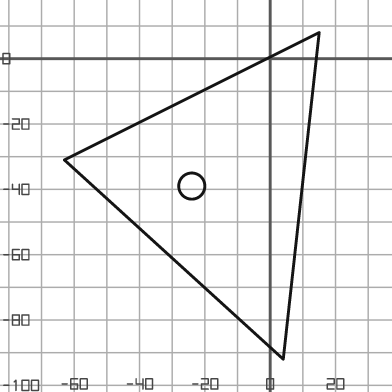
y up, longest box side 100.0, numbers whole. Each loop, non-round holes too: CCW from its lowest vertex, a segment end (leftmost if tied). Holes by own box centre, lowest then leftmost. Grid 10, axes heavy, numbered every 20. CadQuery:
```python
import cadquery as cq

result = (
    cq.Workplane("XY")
    .moveTo(4.0, -92.0)
    .lineTo(15.0, 8.0)
    .lineTo(-63.0, -31.0)
    .close()
    .moveTo(-24.0, -39.0)
    .circle(4.0)
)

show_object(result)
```